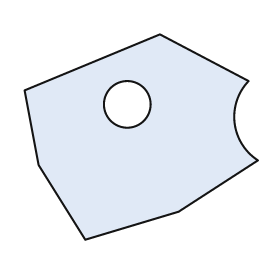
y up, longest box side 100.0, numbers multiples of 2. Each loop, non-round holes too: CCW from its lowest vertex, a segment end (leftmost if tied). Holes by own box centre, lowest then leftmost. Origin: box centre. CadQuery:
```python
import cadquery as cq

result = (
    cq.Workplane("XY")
    .moveTo(-24.0, -44.0)
    .lineTo(16.0, -32.0)
    .lineTo(50.0, -10.0)
    .threePointArc((40.0, 6.0), (46.0, 24.0))
    .lineTo(8.0, 44.0)
    .lineTo(-50.0, 20.0)
    .lineTo(-44.0, -12.0)
    .close()
    .moveTo(-6.0, 14.0)
    .circle(10.0)
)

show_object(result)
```